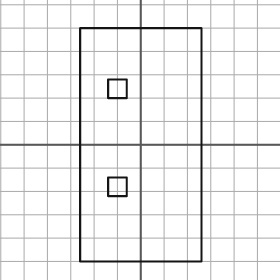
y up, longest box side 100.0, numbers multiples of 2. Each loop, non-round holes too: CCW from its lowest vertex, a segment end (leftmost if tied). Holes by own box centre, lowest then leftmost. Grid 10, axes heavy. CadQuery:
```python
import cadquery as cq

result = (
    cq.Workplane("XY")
    .moveTo(-26.0, -50.0)
    .lineTo(26.0, -50.0)
    .lineTo(26.0, 50.0)
    .lineTo(-26.0, 50.0)
    .close()
    .moveTo(-14.0, -22.0)
    .lineTo(-6.0, -22.0)
    .lineTo(-6.0, -14.0)
    .lineTo(-14.0, -14.0)
    .close()
    .moveTo(-14.0, 20.0)
    .lineTo(-6.0, 20.0)
    .lineTo(-6.0, 28.0)
    .lineTo(-14.0, 28.0)
    .close()
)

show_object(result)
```